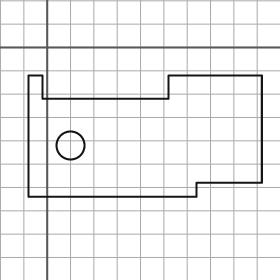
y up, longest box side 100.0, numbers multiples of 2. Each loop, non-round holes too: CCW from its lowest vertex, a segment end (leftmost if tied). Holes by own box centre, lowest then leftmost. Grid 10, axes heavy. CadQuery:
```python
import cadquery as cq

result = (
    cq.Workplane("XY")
    .moveTo(-8.0, -64.0)
    .lineTo(64.0, -64.0)
    .lineTo(64.0, -58.0)
    .lineTo(92.0, -58.0)
    .lineTo(92.0, -12.0)
    .lineTo(52.0, -12.0)
    .lineTo(52.0, -22.0)
    .lineTo(-2.0, -22.0)
    .lineTo(-2.0, -12.0)
    .lineTo(-8.0, -12.0)
    .close()
    .moveTo(10.0, -42.0)
    .circle(6.0)
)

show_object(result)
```